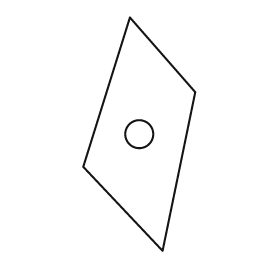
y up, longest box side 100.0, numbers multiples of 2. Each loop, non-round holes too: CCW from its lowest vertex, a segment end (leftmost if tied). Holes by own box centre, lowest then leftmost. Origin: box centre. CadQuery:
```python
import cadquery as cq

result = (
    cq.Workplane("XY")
    .moveTo(10.0, -50.0)
    .lineTo(24.0, 18.0)
    .lineTo(-4.0, 50.0)
    .lineTo(-24.0, -14.0)
    .close()
    .moveTo(0.0, 0.0)
    .circle(6.0)
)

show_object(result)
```